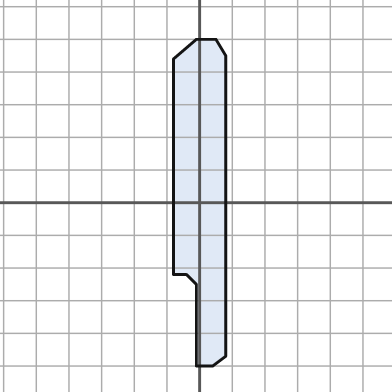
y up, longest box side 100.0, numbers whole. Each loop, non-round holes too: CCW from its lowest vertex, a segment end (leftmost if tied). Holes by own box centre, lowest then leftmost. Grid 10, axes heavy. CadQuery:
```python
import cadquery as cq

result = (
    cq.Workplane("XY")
    .moveTo(-1.0, -50.0)
    .lineTo(4.0, -50.0)
    .lineTo(8.0, -47.0)
    .lineTo(8.0, 45.0)
    .lineTo(5.0, 50.0)
    .lineTo(-1.0, 50.0)
    .lineTo(-8.0, 44.0)
    .lineTo(-8.0, -22.0)
    .lineTo(-4.0, -22.0)
    .lineTo(-1.0, -25.0)
    .close()
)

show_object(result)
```